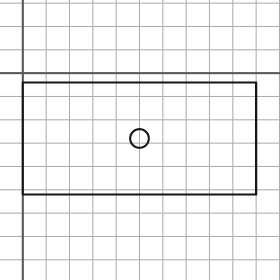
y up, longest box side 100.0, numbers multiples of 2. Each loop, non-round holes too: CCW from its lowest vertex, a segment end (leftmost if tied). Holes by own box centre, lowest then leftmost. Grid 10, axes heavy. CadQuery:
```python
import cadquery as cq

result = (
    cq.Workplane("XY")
    .moveTo(0.0, -52.0)
    .lineTo(100.0, -52.0)
    .lineTo(100.0, -4.0)
    .lineTo(0.0, -4.0)
    .close()
    .moveTo(50.0, -28.0)
    .circle(4.0)
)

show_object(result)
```